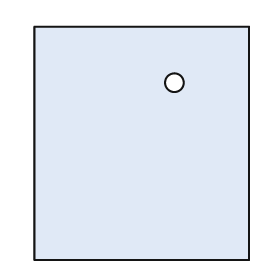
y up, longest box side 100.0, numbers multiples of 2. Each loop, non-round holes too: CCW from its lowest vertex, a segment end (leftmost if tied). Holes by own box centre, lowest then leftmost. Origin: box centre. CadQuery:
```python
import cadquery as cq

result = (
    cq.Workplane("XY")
    .moveTo(-46.0, -50.0)
    .lineTo(46.0, -50.0)
    .lineTo(46.0, 50.0)
    .lineTo(-46.0, 50.0)
    .close()
    .moveTo(14.0, 26.0)
    .circle(4.0)
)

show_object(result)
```